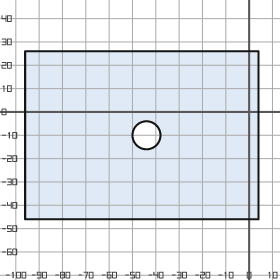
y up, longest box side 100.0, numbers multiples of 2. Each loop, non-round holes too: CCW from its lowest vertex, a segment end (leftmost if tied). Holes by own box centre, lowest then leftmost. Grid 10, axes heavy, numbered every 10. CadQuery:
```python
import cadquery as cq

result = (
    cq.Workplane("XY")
    .moveTo(-96.0, -46.0)
    .lineTo(4.0, -46.0)
    .lineTo(4.0, 26.0)
    .lineTo(-96.0, 26.0)
    .close()
    .moveTo(-44.0, -10.0)
    .circle(6.0)
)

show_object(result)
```